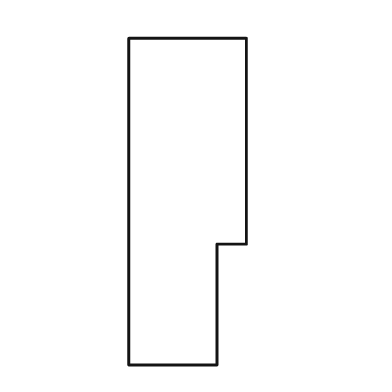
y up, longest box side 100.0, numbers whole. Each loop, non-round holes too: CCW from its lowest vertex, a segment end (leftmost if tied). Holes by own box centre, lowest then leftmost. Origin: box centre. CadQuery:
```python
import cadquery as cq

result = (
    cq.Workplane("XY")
    .moveTo(-18.0, -50.0)
    .lineTo(9.0, -50.0)
    .lineTo(9.0, -13.0)
    .lineTo(18.0, -13.0)
    .lineTo(18.0, 50.0)
    .lineTo(-18.0, 50.0)
    .close()
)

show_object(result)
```